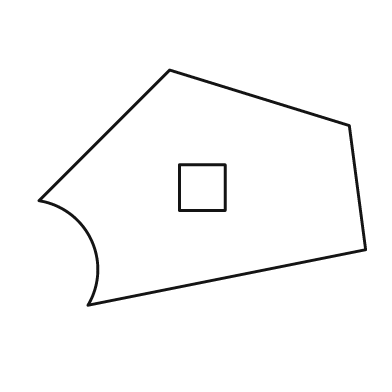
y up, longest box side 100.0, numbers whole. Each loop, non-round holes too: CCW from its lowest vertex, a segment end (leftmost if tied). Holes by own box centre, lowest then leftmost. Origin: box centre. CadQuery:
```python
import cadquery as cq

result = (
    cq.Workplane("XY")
    .moveTo(-35.0, -36.0)
    .lineTo(50.0, -19.0)
    .lineTo(45.0, 19.0)
    .lineTo(-10.0, 36.0)
    .lineTo(-50.0, -4.0)
    .threePointArc((-34.0, -16.0), (-35.0, -36.0))
    .close()
    .moveTo(-7.0, -7.0)
    .lineTo(7.0, -7.0)
    .lineTo(7.0, 7.0)
    .lineTo(-7.0, 7.0)
    .close()
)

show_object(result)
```